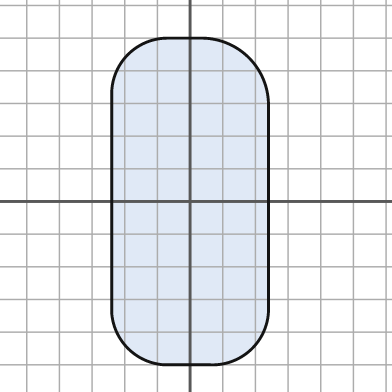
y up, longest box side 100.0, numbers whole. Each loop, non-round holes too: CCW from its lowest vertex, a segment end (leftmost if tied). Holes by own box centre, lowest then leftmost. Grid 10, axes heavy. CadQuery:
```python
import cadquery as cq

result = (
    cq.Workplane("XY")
    .moveTo(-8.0, -50.0)
    .lineTo(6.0, -50.0)
    .threePointArc((19.0, -45.0), (24.0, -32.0))
    .lineTo(24.0, 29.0)
    .threePointArc((18.0, 44.0), (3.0, 50.0))
    .lineTo(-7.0, 50.0)
    .threePointArc((-19.0, 45.0), (-24.0, 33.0))
    .lineTo(-24.0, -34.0)
    .threePointArc((-19.0, -45.0), (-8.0, -50.0))
    .close()
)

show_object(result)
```